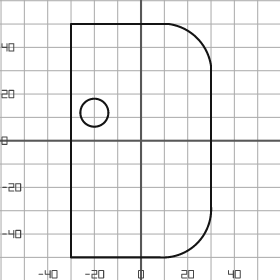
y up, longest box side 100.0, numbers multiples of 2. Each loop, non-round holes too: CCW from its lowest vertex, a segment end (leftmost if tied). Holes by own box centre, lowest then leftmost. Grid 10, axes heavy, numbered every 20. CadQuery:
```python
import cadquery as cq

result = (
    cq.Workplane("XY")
    .moveTo(-30.0, -50.0)
    .lineTo(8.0, -50.0)
    .threePointArc((24.0, -44.0), (30.0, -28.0))
    .lineTo(30.0, 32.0)
    .threePointArc((24.0, 44.0), (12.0, 50.0))
    .lineTo(-30.0, 50.0)
    .close()
    .moveTo(-20.0, 12.0)
    .circle(6.0)
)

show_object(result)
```